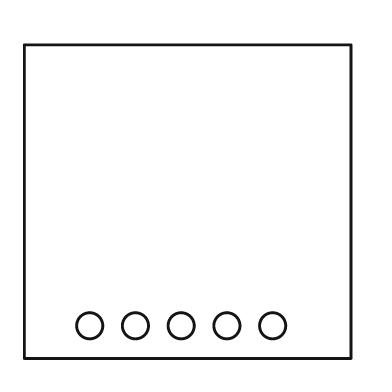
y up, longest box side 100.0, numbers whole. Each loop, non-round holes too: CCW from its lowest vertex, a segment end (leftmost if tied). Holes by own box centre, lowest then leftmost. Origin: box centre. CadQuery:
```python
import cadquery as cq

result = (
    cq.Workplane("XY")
    .moveTo(-50.0, -48.0)
    .lineTo(50.0, -48.0)
    .lineTo(50.0, 48.0)
    .lineTo(-50.0, 48.0)
    .close()
    .moveTo(-30.0, -38.0)
    .circle(4.0)
    .moveTo(-16.0, -38.0)
    .circle(4.0)
    .moveTo(-2.0, -38.0)
    .circle(4.0)
    .moveTo(12.0, -38.0)
    .circle(4.0)
    .moveTo(26.0, -38.0)
    .circle(4.0)
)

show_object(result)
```